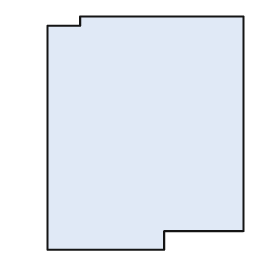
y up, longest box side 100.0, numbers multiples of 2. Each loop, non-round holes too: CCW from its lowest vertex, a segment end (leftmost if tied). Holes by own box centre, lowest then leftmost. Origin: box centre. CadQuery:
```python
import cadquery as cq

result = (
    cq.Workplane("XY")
    .moveTo(-42.0, -50.0)
    .lineTo(8.0, -50.0)
    .lineTo(8.0, -42.0)
    .lineTo(42.0, -42.0)
    .lineTo(42.0, 50.0)
    .lineTo(-28.0, 50.0)
    .lineTo(-28.0, 46.0)
    .lineTo(-42.0, 46.0)
    .close()
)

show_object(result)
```